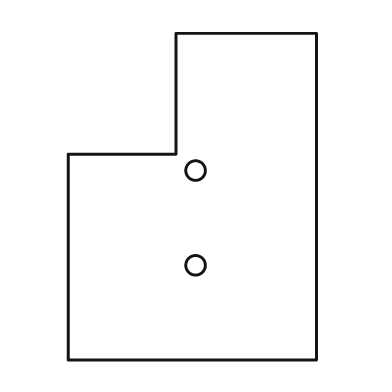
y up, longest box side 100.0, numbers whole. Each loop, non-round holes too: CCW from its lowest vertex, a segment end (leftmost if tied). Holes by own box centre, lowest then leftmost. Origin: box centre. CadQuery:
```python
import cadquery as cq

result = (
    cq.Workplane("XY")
    .moveTo(-38.0, -50.0)
    .lineTo(38.0, -50.0)
    .lineTo(38.0, 50.0)
    .lineTo(-5.0, 50.0)
    .lineTo(-5.0, 13.0)
    .lineTo(-38.0, 13.0)
    .close()
    .moveTo(1.0, -21.0)
    .circle(3.0)
    .moveTo(1.0, 8.0)
    .circle(3.0)
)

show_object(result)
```